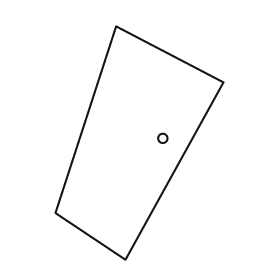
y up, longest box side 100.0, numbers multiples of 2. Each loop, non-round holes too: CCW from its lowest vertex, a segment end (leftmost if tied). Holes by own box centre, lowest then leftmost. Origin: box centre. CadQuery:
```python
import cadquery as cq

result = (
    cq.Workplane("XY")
    .moveTo(-6.0, -50.0)
    .lineTo(36.0, 26.0)
    .lineTo(-10.0, 50.0)
    .lineTo(-36.0, -30.0)
    .close()
    .moveTo(10.0, 2.0)
    .circle(2.0)
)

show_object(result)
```